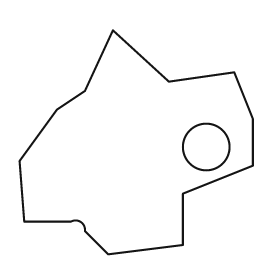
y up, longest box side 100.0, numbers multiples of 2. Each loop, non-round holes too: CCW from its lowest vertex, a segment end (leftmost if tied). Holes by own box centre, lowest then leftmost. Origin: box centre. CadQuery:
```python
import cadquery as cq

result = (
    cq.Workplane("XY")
    .moveTo(-12.0, -48.0)
    .lineTo(20.0, -44.0)
    .lineTo(20.0, -22.0)
    .lineTo(50.0, -10.0)
    .lineTo(50.0, 10.0)
    .lineTo(42.0, 30.0)
    .lineTo(14.0, 26.0)
    .lineTo(-10.0, 48.0)
    .lineTo(-22.0, 22.0)
    .lineTo(-34.0, 14.0)
    .lineTo(-50.0, -8.0)
    .lineTo(-48.0, -34.0)
    .lineTo(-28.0, -34.0)
    .threePointArc((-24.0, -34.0), (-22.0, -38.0))
    .close()
    .moveTo(30.0, -2.0)
    .circle(10.0)
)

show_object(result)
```